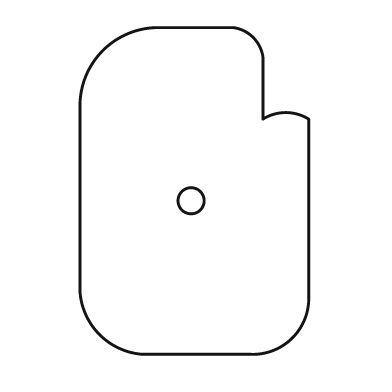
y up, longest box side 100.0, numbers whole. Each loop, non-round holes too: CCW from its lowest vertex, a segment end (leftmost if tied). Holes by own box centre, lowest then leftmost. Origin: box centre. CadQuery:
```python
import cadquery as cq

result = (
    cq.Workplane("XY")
    .moveTo(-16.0, -50.0)
    .lineTo(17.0, -50.0)
    .threePointArc((30.0, -45.0), (35.0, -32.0))
    .lineTo(35.0, 22.0)
    .threePointArc((28.0, 24.0), (21.0, 22.0))
    .lineTo(21.0, 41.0)
    .threePointArc((18.0, 47.0), (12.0, 50.0))
    .lineTo(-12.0, 50.0)
    .threePointArc((-28.0, 43.0), (-35.0, 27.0))
    .lineTo(-35.0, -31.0)
    .threePointArc((-29.0, -44.0), (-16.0, -50.0))
    .close()
    .moveTo(-1.0, -3.0)
    .circle(4.0)
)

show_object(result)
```